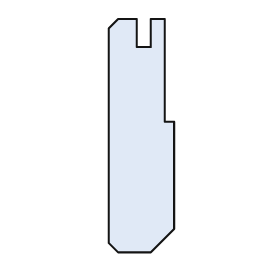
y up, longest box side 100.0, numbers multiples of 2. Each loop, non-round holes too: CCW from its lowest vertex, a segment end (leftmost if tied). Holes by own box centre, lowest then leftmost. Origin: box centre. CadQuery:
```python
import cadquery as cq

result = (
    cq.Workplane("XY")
    .moveTo(-10.0, -50.0)
    .lineTo(4.0, -50.0)
    .lineTo(14.0, -40.0)
    .lineTo(14.0, 6.0)
    .lineTo(10.0, 6.0)
    .lineTo(10.0, 50.0)
    .lineTo(4.0, 50.0)
    .lineTo(4.0, 38.0)
    .lineTo(-2.0, 38.0)
    .lineTo(-2.0, 50.0)
    .lineTo(-10.0, 50.0)
    .lineTo(-14.0, 46.0)
    .lineTo(-14.0, -46.0)
    .close()
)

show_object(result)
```